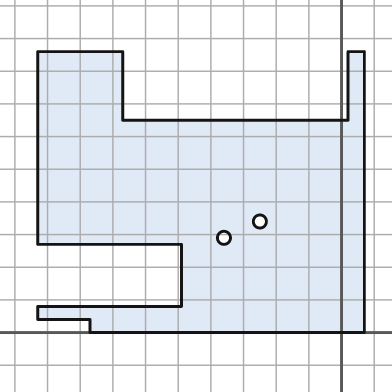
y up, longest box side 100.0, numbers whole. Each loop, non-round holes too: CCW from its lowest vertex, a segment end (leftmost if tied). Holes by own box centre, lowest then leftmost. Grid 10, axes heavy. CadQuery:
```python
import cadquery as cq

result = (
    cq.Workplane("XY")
    .moveTo(-77.0, 0.0)
    .lineTo(7.0, 0.0)
    .lineTo(7.0, 86.0)
    .lineTo(2.0, 86.0)
    .lineTo(2.0, 65.0)
    .lineTo(-67.0, 65.0)
    .lineTo(-67.0, 86.0)
    .lineTo(-93.0, 86.0)
    .lineTo(-93.0, 27.0)
    .lineTo(-49.0, 27.0)
    .lineTo(-49.0, 8.0)
    .lineTo(-93.0, 8.0)
    .lineTo(-93.0, 4.0)
    .lineTo(-77.0, 4.0)
    .close()
    .moveTo(-36.0, 29.0)
    .circle(2.0)
    .moveTo(-25.0, 34.0)
    .circle(2.0)
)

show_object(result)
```